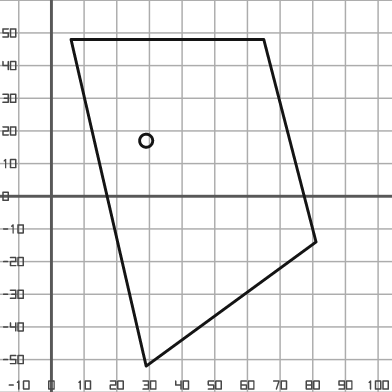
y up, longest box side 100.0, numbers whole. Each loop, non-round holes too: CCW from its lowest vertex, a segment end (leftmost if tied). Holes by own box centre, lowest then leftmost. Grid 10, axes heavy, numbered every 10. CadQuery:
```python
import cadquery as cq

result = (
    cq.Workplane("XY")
    .moveTo(29.0, -52.0)
    .lineTo(81.0, -14.0)
    .lineTo(65.0, 48.0)
    .lineTo(6.0, 48.0)
    .close()
    .moveTo(29.0, 17.0)
    .circle(2.0)
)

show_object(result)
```